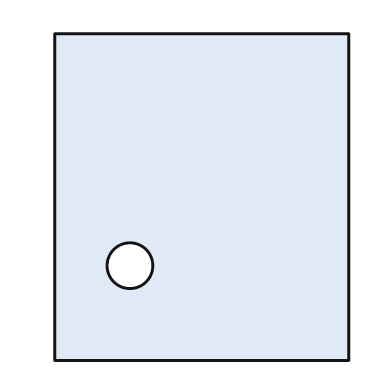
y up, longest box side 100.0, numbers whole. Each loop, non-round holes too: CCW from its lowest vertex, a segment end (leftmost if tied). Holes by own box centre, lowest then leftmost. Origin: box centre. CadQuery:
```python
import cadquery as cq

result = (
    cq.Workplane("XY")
    .moveTo(-45.0, -50.0)
    .lineTo(45.0, -50.0)
    .lineTo(45.0, 50.0)
    .lineTo(-45.0, 50.0)
    .close()
    .moveTo(-22.0, -21.0)
    .circle(7.0)
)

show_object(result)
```